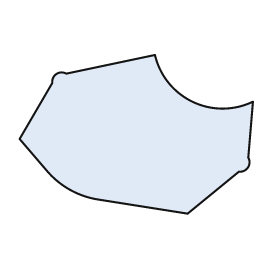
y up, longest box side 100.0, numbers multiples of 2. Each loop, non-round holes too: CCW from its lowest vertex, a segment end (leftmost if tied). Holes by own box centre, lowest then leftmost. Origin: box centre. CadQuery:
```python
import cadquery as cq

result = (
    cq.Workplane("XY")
    .moveTo(22.0, -34.0)
    .lineTo(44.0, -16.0)
    .threePointArc((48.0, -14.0), (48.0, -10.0))
    .lineTo(50.0, 14.0)
    .threePointArc((24.0, 14.0), (8.0, 34.0))
    .lineTo(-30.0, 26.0)
    .threePointArc((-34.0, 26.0), (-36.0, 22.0))
    .lineTo(-50.0, -2.0)
    .lineTo(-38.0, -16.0)
    .threePointArc((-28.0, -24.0), (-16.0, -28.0))
    .close()
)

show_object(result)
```